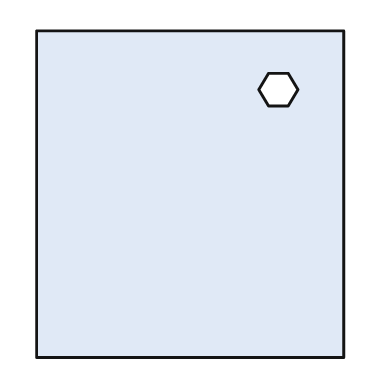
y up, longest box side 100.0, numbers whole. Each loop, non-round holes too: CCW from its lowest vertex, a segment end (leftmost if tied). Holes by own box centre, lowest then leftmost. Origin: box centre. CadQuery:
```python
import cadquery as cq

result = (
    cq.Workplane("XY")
    .moveTo(-47.0, -50.0)
    .lineTo(47.0, -50.0)
    .lineTo(47.0, 50.0)
    .lineTo(-47.0, 50.0)
    .close()
    .moveTo(24.0, 27.0)
    .lineTo(30.0, 27.0)
    .lineTo(33.0, 32.0)
    .lineTo(30.0, 37.0)
    .lineTo(24.0, 37.0)
    .lineTo(21.0, 32.0)
    .close()
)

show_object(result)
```